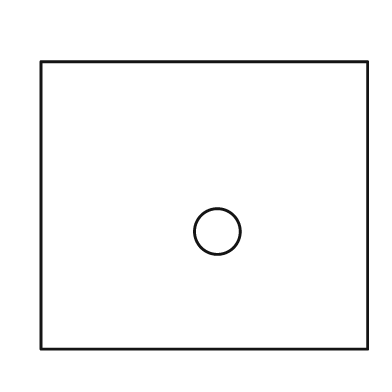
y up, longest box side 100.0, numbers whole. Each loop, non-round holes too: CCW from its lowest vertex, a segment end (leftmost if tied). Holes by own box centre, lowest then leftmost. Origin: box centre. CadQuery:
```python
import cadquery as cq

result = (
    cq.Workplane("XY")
    .moveTo(-50.0, -44.0)
    .lineTo(50.0, -44.0)
    .lineTo(50.0, 44.0)
    .lineTo(-50.0, 44.0)
    .close()
    .moveTo(4.0, -8.0)
    .circle(7.0)
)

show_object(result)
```